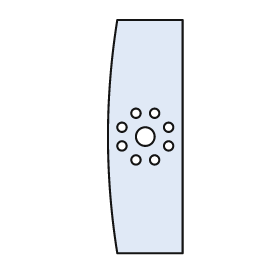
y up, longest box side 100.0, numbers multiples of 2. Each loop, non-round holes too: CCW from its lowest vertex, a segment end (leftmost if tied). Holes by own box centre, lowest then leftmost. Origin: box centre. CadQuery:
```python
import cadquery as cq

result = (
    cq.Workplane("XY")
    .moveTo(-12.0, -50.0)
    .lineTo(16.0, -50.0)
    .lineTo(16.0, 50.0)
    .lineTo(-12.0, 50.0)
    .threePointArc((-16.0, 0.0), (-12.0, -50.0))
    .close()
    .moveTo(-4.0, -10.0)
    .circle(2.0)
    .moveTo(4.0, -10.0)
    .circle(2.0)
    .moveTo(-10.0, -4.0)
    .circle(2.0)
    .moveTo(10.0, -4.0)
    .circle(2.0)
    .moveTo(0.0, 0.0)
    .circle(4.0)
    .moveTo(-10.0, 4.0)
    .circle(2.0)
    .moveTo(10.0, 4.0)
    .circle(2.0)
    .moveTo(-4.0, 10.0)
    .circle(2.0)
    .moveTo(4.0, 10.0)
    .circle(2.0)
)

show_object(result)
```